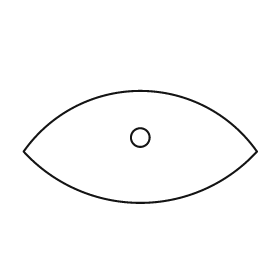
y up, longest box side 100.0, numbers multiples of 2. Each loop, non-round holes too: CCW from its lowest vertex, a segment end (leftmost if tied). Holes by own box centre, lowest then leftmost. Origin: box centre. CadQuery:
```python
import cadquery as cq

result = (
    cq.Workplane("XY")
    .moveTo(-50.0, -2.0)
    .threePointArc((0.0, -24.0), (50.0, -2.0))
    .threePointArc((0.0, 24.0), (-50.0, -2.0))
    .close()
    .moveTo(0.0, 4.0)
    .circle(4.0)
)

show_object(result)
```